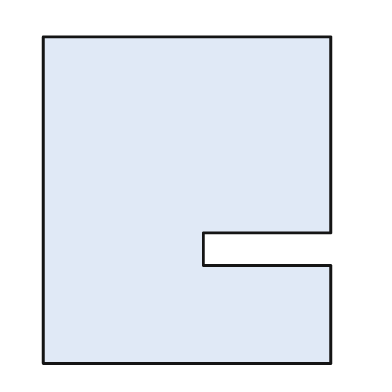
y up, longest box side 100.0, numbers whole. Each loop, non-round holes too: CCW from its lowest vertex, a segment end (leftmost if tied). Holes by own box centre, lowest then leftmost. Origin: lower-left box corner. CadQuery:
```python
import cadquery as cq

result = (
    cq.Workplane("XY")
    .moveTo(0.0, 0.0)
    .lineTo(88.0, 0.0)
    .lineTo(88.0, 30.0)
    .lineTo(49.0, 30.0)
    .lineTo(49.0, 40.0)
    .lineTo(88.0, 40.0)
    .lineTo(88.0, 100.0)
    .lineTo(0.0, 100.0)
    .close()
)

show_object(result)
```